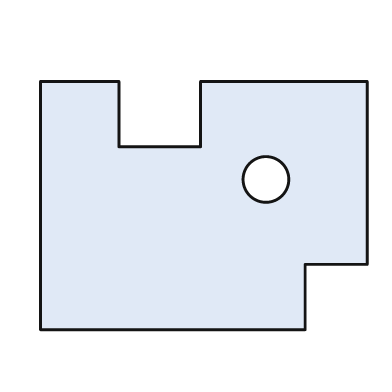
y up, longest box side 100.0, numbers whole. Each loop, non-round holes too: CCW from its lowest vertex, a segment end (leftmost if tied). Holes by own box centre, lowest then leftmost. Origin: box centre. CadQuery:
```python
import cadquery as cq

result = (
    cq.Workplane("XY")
    .moveTo(-50.0, -38.0)
    .lineTo(31.0, -38.0)
    .lineTo(31.0, -18.0)
    .lineTo(50.0, -18.0)
    .lineTo(50.0, 38.0)
    .lineTo(-1.0, 38.0)
    .lineTo(-1.0, 18.0)
    .lineTo(-26.0, 18.0)
    .lineTo(-26.0, 38.0)
    .lineTo(-50.0, 38.0)
    .close()
    .moveTo(19.0, 8.0)
    .circle(7.0)
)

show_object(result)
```